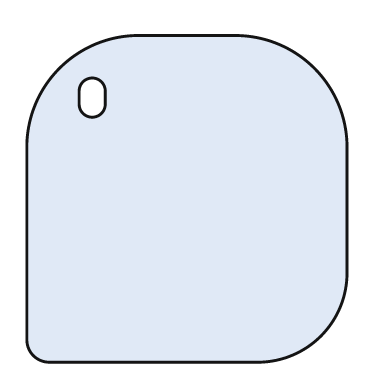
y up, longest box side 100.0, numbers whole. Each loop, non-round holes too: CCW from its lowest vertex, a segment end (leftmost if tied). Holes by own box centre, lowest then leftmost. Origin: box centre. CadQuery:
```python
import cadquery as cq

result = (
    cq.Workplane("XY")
    .moveTo(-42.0, -50.0)
    .lineTo(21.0, -50.0)
    .threePointArc((41.0, -42.0), (49.0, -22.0))
    .lineTo(49.0, 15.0)
    .threePointArc((39.0, 40.0), (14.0, 50.0))
    .lineTo(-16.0, 50.0)
    .threePointArc((-39.0, 40.0), (-49.0, 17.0))
    .lineTo(-49.0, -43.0)
    .threePointArc((-47.0, -48.0), (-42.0, -50.0))
    .close()
    .moveTo(-33.0, 29.0)
    .threePointArc((-29.0, 25.0), (-25.0, 29.0))
    .lineTo(-25.0, 33.0)
    .threePointArc((-29.0, 37.0), (-33.0, 33.0))
    .close()
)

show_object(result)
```